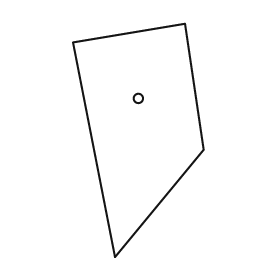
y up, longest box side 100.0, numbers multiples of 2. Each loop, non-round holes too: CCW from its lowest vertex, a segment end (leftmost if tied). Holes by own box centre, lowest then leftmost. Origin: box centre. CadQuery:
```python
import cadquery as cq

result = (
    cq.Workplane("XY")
    .moveTo(-10.0, -50.0)
    .lineTo(28.0, -4.0)
    .lineTo(20.0, 50.0)
    .lineTo(-28.0, 42.0)
    .close()
    .moveTo(0.0, 18.0)
    .circle(2.0)
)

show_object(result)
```